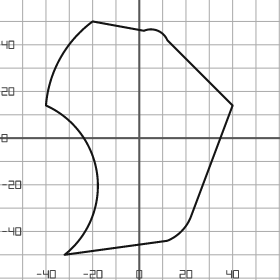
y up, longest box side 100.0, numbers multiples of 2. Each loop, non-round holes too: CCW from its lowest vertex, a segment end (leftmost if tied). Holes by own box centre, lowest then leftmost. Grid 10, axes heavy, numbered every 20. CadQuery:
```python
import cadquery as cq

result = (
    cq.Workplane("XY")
    .moveTo(-32.0, -50.0)
    .lineTo(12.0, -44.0)
    .threePointArc((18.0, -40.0), (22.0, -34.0))
    .lineTo(40.0, 14.0)
    .lineTo(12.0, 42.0)
    .threePointArc((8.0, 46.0), (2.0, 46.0))
    .lineTo(-20.0, 50.0)
    .threePointArc((-34.0, 34.0), (-40.0, 14.0))
    .threePointArc((-18.0, -16.0), (-32.0, -50.0))
    .close()
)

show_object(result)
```